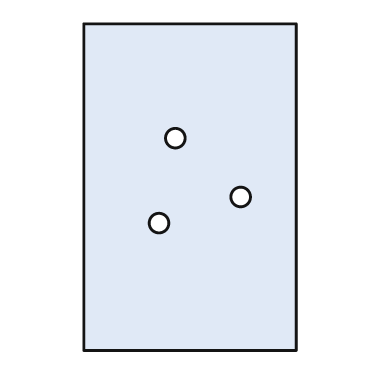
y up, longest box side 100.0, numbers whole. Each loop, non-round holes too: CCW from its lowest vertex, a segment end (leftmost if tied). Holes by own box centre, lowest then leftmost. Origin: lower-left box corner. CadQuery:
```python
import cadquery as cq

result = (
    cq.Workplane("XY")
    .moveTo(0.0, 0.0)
    .lineTo(65.0, 0.0)
    .lineTo(65.0, 100.0)
    .lineTo(0.0, 100.0)
    .close()
    .moveTo(23.0, 39.0)
    .circle(3.0)
    .moveTo(48.0, 47.0)
    .circle(3.0)
    .moveTo(28.0, 65.0)
    .circle(3.0)
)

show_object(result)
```